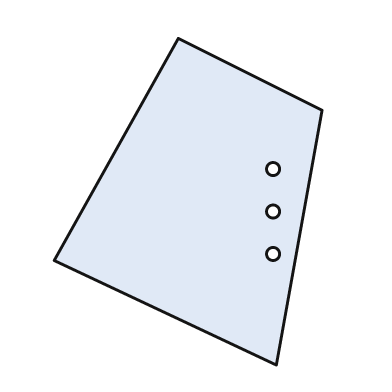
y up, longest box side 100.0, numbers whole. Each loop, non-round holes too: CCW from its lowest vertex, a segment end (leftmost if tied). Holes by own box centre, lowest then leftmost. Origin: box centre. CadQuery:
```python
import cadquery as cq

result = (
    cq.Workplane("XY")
    .moveTo(27.0, -50.0)
    .lineTo(41.0, 28.0)
    .lineTo(-3.0, 50.0)
    .lineTo(-41.0, -18.0)
    .close()
    .moveTo(26.0, -16.0)
    .circle(2.0)
    .moveTo(26.0, -3.0)
    .circle(2.0)
    .moveTo(26.0, 10.0)
    .circle(2.0)
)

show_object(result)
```